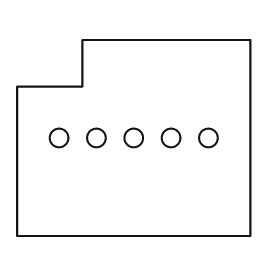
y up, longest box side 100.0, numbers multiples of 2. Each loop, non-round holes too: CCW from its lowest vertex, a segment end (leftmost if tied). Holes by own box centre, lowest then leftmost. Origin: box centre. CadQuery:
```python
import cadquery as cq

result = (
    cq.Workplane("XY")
    .moveTo(-50.0, -42.0)
    .lineTo(50.0, -42.0)
    .lineTo(50.0, 42.0)
    .lineTo(-22.0, 42.0)
    .lineTo(-22.0, 22.0)
    .lineTo(-50.0, 22.0)
    .close()
    .moveTo(-32.0, 0.0)
    .circle(4.0)
    .moveTo(-16.0, 0.0)
    .circle(4.0)
    .moveTo(0.0, 0.0)
    .circle(4.0)
    .moveTo(16.0, 0.0)
    .circle(4.0)
    .moveTo(32.0, 0.0)
    .circle(4.0)
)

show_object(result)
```